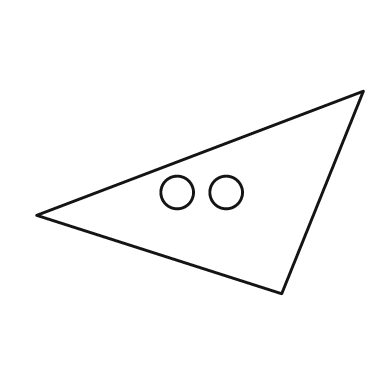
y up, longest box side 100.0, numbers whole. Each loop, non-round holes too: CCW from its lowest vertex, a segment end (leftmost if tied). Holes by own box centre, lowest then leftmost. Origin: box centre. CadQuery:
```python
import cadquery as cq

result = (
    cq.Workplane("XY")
    .moveTo(25.0, -31.0)
    .lineTo(50.0, 31.0)
    .lineTo(-50.0, -7.0)
    .close()
    .moveTo(-7.0, 0.0)
    .circle(5.0)
    .moveTo(8.0, 0.0)
    .circle(5.0)
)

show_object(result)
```